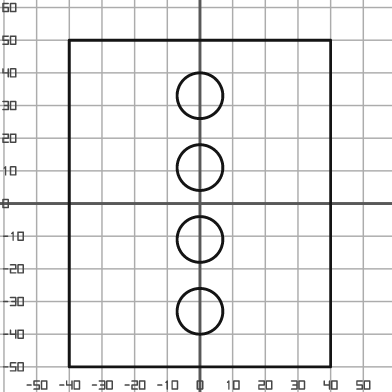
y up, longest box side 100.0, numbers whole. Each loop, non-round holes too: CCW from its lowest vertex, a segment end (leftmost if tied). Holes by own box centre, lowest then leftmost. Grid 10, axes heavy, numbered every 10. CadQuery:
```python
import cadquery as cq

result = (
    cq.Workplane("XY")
    .moveTo(-40.0, -50.0)
    .lineTo(40.0, -50.0)
    .lineTo(40.0, 50.0)
    .lineTo(-40.0, 50.0)
    .close()
    .moveTo(0.0, -33.0)
    .circle(7.0)
    .moveTo(0.0, -11.0)
    .circle(7.0)
    .moveTo(0.0, 11.0)
    .circle(7.0)
    .moveTo(0.0, 33.0)
    .circle(7.0)
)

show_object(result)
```